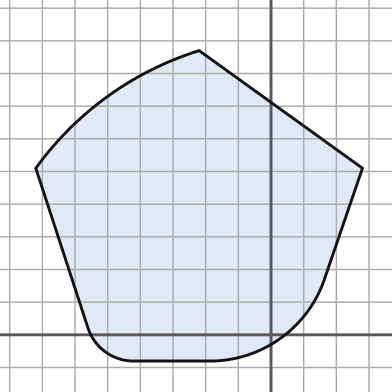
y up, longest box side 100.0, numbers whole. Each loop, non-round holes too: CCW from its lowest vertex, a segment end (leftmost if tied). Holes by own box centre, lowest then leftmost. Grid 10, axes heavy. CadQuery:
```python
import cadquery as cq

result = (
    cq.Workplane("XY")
    .moveTo(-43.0, -8.0)
    .lineTo(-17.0, -8.0)
    .threePointArc((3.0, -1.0), (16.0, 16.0))
    .lineTo(28.0, 51.0)
    .lineTo(-22.0, 87.0)
    .threePointArc((-50.0, 73.0), (-72.0, 51.0))
    .lineTo(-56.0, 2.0)
    .threePointArc((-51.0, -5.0), (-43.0, -8.0))
    .close()
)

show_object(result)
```